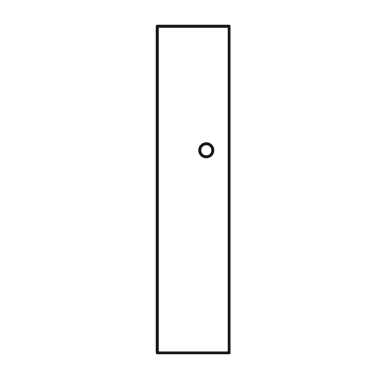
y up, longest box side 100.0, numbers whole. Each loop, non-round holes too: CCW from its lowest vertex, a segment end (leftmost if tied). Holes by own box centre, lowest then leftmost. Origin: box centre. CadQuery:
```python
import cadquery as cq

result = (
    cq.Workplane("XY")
    .moveTo(-11.0, -50.0)
    .lineTo(11.0, -50.0)
    .lineTo(11.0, 50.0)
    .lineTo(-11.0, 50.0)
    .close()
    .moveTo(4.0, 12.0)
    .circle(2.0)
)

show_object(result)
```